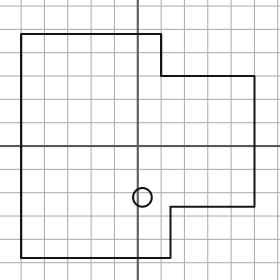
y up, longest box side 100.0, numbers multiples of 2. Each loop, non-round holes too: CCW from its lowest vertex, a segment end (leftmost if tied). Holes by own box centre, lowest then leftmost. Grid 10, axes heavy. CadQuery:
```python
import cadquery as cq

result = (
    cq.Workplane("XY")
    .moveTo(-50.0, -48.0)
    .lineTo(14.0, -48.0)
    .lineTo(14.0, -26.0)
    .lineTo(50.0, -26.0)
    .lineTo(50.0, 30.0)
    .lineTo(10.0, 30.0)
    .lineTo(10.0, 48.0)
    .lineTo(-50.0, 48.0)
    .close()
    .moveTo(2.0, -22.0)
    .circle(4.0)
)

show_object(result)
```